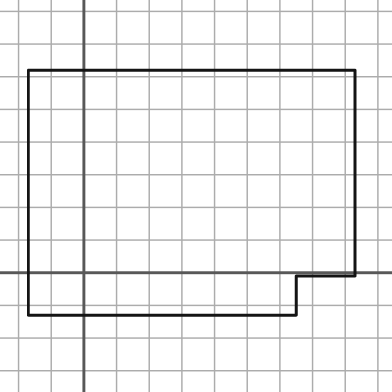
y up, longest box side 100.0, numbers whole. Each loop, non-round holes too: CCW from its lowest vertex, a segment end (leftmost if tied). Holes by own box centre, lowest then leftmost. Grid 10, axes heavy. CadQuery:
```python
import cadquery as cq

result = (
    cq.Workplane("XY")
    .moveTo(-17.0, -13.0)
    .lineTo(65.0, -13.0)
    .lineTo(65.0, -1.0)
    .lineTo(83.0, -1.0)
    .lineTo(83.0, 62.0)
    .lineTo(-17.0, 62.0)
    .close()
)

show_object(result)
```